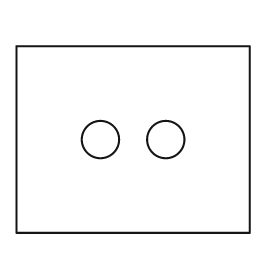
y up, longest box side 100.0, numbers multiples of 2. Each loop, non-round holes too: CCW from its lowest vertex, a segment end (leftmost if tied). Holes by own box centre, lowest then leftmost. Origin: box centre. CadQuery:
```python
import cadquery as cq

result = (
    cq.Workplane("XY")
    .moveTo(-50.0, -40.0)
    .lineTo(50.0, -40.0)
    .lineTo(50.0, 40.0)
    .lineTo(-50.0, 40.0)
    .close()
    .moveTo(-14.0, 0.0)
    .circle(8.0)
    .moveTo(14.0, 0.0)
    .circle(8.0)
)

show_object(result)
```